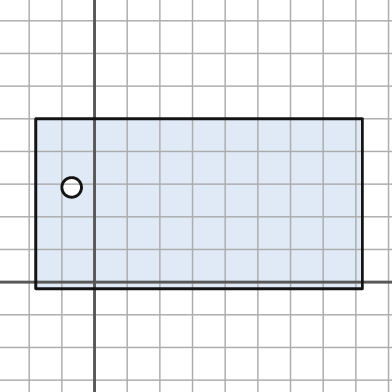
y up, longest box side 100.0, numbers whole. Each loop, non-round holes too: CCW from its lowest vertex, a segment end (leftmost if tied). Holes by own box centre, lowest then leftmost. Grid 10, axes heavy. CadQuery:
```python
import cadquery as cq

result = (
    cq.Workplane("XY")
    .moveTo(-18.0, -2.0)
    .lineTo(82.0, -2.0)
    .lineTo(82.0, 50.0)
    .lineTo(-18.0, 50.0)
    .close()
    .moveTo(-7.0, 29.0)
    .circle(3.0)
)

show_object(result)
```